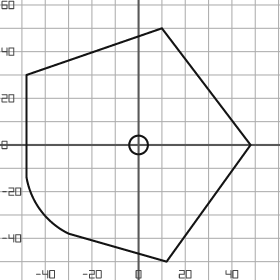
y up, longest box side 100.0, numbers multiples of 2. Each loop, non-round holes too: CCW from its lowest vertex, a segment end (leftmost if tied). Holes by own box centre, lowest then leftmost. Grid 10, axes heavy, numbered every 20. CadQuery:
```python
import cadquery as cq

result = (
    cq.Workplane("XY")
    .moveTo(12.0, -50.0)
    .lineTo(48.0, 0.0)
    .lineTo(10.0, 50.0)
    .lineTo(-48.0, 30.0)
    .lineTo(-48.0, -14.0)
    .threePointArc((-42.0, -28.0), (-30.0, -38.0))
    .close()
    .moveTo(0.0, 0.0)
    .circle(4.0)
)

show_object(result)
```